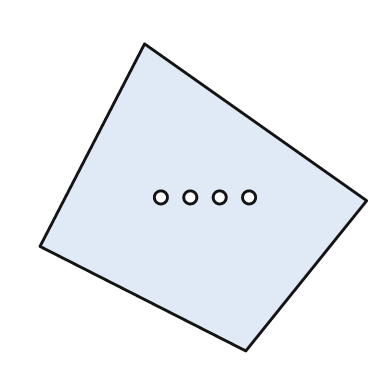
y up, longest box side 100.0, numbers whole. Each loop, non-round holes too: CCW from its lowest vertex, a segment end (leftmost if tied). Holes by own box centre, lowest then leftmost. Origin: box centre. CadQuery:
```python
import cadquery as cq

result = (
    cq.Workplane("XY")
    .moveTo(13.0, -47.0)
    .lineTo(50.0, -1.0)
    .lineTo(-18.0, 47.0)
    .lineTo(-50.0, -15.0)
    .close()
    .moveTo(-13.0, 0.0)
    .circle(2.0)
    .moveTo(-4.0, 0.0)
    .circle(2.0)
    .moveTo(5.0, 0.0)
    .circle(2.0)
    .moveTo(14.0, 0.0)
    .circle(2.0)
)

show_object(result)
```